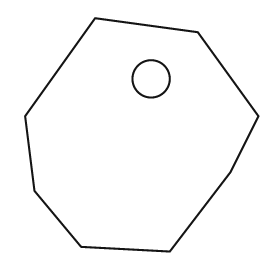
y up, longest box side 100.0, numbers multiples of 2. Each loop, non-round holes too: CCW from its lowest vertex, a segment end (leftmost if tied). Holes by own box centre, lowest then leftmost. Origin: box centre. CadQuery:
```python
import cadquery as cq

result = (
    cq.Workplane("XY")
    .moveTo(12.0, -50.0)
    .lineTo(38.0, -16.0)
    .lineTo(50.0, 8.0)
    .lineTo(24.0, 44.0)
    .lineTo(-20.0, 50.0)
    .lineTo(-50.0, 8.0)
    .lineTo(-46.0, -24.0)
    .lineTo(-26.0, -48.0)
    .close()
    .moveTo(4.0, 24.0)
    .circle(8.0)
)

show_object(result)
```